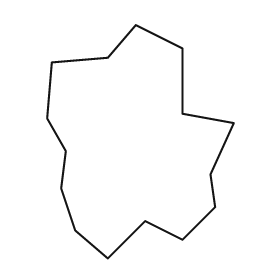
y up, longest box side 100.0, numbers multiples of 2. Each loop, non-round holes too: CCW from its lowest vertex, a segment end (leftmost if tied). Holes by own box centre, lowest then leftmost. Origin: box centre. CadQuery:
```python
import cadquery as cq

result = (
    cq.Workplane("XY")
    .moveTo(-14.0, -50.0)
    .lineTo(2.0, -34.0)
    .lineTo(18.0, -42.0)
    .lineTo(32.0, -28.0)
    .lineTo(30.0, -14.0)
    .lineTo(40.0, 8.0)
    .lineTo(18.0, 12.0)
    .lineTo(18.0, 40.0)
    .lineTo(-2.0, 50.0)
    .lineTo(-14.0, 36.0)
    .lineTo(-38.0, 34.0)
    .lineTo(-40.0, 10.0)
    .lineTo(-32.0, -4.0)
    .lineTo(-34.0, -20.0)
    .lineTo(-28.0, -38.0)
    .close()
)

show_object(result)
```